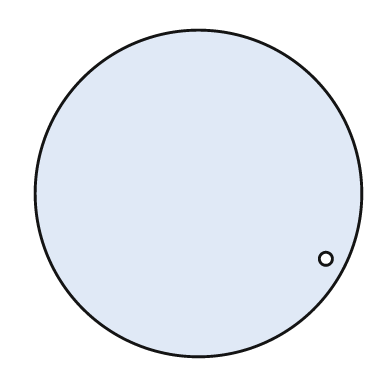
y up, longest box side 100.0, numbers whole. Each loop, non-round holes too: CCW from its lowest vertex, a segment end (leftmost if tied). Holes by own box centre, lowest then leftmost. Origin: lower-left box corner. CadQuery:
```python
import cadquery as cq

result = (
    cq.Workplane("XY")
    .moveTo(50.0, 50.0)
    .circle(50.0)
    .moveTo(89.0, 30.0)
    .circle(2.0)
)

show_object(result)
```